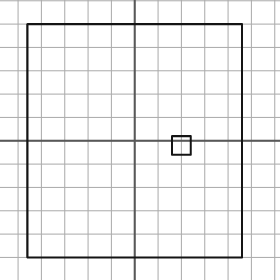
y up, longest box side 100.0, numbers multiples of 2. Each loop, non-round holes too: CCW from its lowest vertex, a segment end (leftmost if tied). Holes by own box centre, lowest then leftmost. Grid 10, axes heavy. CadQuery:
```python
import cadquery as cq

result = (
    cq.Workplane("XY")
    .moveTo(-46.0, -50.0)
    .lineTo(46.0, -50.0)
    .lineTo(46.0, 50.0)
    .lineTo(-46.0, 50.0)
    .close()
    .moveTo(16.0, -6.0)
    .lineTo(24.0, -6.0)
    .lineTo(24.0, 2.0)
    .lineTo(16.0, 2.0)
    .close()
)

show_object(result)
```